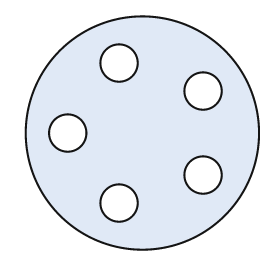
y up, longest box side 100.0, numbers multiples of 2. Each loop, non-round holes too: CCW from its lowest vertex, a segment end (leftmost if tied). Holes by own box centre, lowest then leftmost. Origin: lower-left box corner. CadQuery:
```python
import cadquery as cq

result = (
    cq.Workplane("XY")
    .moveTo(50.0, 50.0)
    .circle(50.0)
    .moveTo(40.0, 20.0)
    .circle(8.0)
    .moveTo(76.0, 32.0)
    .circle(8.0)
    .moveTo(18.0, 50.0)
    .circle(8.0)
    .moveTo(76.0, 68.0)
    .circle(8.0)
    .moveTo(40.0, 80.0)
    .circle(8.0)
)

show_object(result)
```